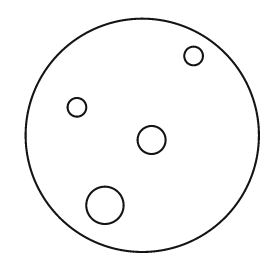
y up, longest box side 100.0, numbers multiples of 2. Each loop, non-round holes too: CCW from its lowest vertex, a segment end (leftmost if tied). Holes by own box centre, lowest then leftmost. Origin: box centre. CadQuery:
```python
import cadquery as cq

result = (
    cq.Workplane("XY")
    .moveTo(0.0, 0.0)
    .circle(50.0)
    .moveTo(-16.0, -30.0)
    .circle(8.0)
    .moveTo(4.0, -2.0)
    .circle(6.0)
    .moveTo(-28.0, 12.0)
    .circle(4.0)
    .moveTo(22.0, 34.0)
    .circle(4.0)
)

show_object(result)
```